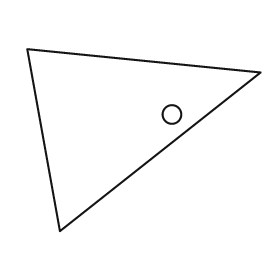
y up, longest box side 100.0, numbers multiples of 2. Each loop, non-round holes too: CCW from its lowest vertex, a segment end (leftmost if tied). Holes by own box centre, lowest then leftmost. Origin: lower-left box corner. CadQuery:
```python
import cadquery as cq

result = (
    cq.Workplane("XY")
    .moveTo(14.0, 0.0)
    .lineTo(100.0, 68.0)
    .lineTo(0.0, 78.0)
    .close()
    .moveTo(62.0, 50.0)
    .circle(4.0)
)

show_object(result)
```